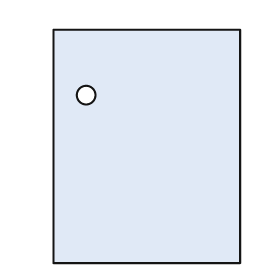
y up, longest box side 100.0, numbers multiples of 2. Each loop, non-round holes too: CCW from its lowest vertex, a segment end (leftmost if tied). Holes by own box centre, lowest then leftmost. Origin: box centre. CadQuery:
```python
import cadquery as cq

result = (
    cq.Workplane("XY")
    .moveTo(-40.0, -50.0)
    .lineTo(40.0, -50.0)
    .lineTo(40.0, 50.0)
    .lineTo(-40.0, 50.0)
    .close()
    .moveTo(-26.0, 22.0)
    .circle(4.0)
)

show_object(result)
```